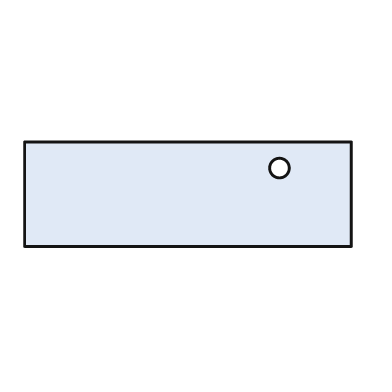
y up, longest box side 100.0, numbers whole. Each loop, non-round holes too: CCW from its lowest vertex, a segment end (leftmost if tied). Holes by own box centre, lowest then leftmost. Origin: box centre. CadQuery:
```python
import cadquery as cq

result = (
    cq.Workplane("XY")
    .moveTo(-50.0, -16.0)
    .lineTo(50.0, -16.0)
    .lineTo(50.0, 16.0)
    .lineTo(-50.0, 16.0)
    .close()
    .moveTo(28.0, 8.0)
    .circle(3.0)
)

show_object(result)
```